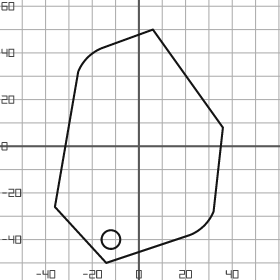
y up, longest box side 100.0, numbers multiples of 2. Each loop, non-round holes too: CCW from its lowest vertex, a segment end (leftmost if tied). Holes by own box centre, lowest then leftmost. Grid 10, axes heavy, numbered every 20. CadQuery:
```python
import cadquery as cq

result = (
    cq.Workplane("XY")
    .moveTo(-14.0, -50.0)
    .lineTo(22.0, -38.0)
    .threePointArc((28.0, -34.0), (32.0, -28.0))
    .lineTo(36.0, 8.0)
    .lineTo(6.0, 50.0)
    .lineTo(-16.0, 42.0)
    .threePointArc((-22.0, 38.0), (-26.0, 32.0))
    .lineTo(-36.0, -26.0)
    .close()
    .moveTo(-12.0, -40.0)
    .circle(4.0)
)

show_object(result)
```